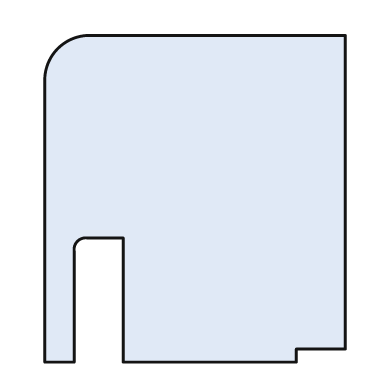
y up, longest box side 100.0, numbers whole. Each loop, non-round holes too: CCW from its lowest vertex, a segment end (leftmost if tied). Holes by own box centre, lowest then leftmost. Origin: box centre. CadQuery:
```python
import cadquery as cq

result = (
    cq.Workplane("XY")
    .moveTo(-46.0, -50.0)
    .lineTo(-37.0, -50.0)
    .lineTo(-37.0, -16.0)
    .threePointArc((-36.0, -13.0), (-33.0, -12.0))
    .lineTo(-22.0, -12.0)
    .lineTo(-22.0, -50.0)
    .lineTo(31.0, -50.0)
    .lineTo(31.0, -46.0)
    .lineTo(46.0, -46.0)
    .lineTo(46.0, 50.0)
    .lineTo(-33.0, 50.0)
    .threePointArc((-42.0, 46.0), (-46.0, 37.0))
    .close()
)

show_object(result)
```